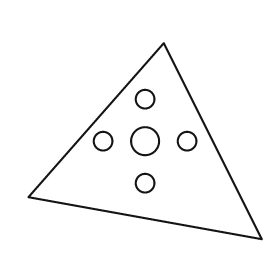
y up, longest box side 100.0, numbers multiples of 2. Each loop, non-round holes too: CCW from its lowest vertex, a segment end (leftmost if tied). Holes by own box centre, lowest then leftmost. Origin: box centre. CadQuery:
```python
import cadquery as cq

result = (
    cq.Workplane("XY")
    .moveTo(50.0, -42.0)
    .lineTo(8.0, 42.0)
    .lineTo(-50.0, -24.0)
    .close()
    .moveTo(0.0, -18.0)
    .circle(4.0)
    .moveTo(-18.0, 0.0)
    .circle(4.0)
    .moveTo(0.0, 0.0)
    .circle(6.0)
    .moveTo(18.0, 0.0)
    .circle(4.0)
    .moveTo(0.0, 18.0)
    .circle(4.0)
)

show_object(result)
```